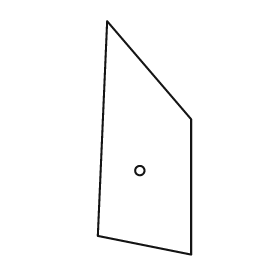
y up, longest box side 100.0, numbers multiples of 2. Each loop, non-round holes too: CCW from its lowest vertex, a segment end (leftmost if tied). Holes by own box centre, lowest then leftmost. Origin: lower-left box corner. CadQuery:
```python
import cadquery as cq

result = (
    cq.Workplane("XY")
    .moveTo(40.0, 0.0)
    .lineTo(40.0, 58.0)
    .lineTo(4.0, 100.0)
    .lineTo(0.0, 8.0)
    .close()
    .moveTo(18.0, 36.0)
    .circle(2.0)
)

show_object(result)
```